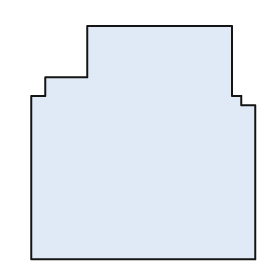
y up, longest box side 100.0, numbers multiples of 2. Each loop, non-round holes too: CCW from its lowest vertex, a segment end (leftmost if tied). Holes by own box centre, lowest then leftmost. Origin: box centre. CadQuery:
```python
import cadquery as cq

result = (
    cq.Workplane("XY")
    .moveTo(-48.0, -50.0)
    .lineTo(48.0, -50.0)
    .lineTo(48.0, 16.0)
    .lineTo(42.0, 16.0)
    .lineTo(42.0, 20.0)
    .lineTo(38.0, 20.0)
    .lineTo(38.0, 50.0)
    .lineTo(-24.0, 50.0)
    .lineTo(-24.0, 28.0)
    .lineTo(-42.0, 28.0)
    .lineTo(-42.0, 20.0)
    .lineTo(-48.0, 20.0)
    .close()
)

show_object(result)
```